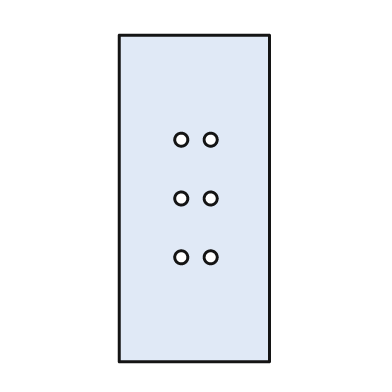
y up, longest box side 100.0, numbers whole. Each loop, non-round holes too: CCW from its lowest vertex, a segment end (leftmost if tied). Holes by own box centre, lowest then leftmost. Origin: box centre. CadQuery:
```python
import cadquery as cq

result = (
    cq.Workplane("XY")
    .moveTo(-23.0, -50.0)
    .lineTo(23.0, -50.0)
    .lineTo(23.0, 50.0)
    .lineTo(-23.0, 50.0)
    .close()
    .moveTo(-4.0, -18.0)
    .circle(2.0)
    .moveTo(5.0, -18.0)
    .circle(2.0)
    .moveTo(-4.0, 0.0)
    .circle(2.0)
    .moveTo(5.0, 0.0)
    .circle(2.0)
    .moveTo(-4.0, 18.0)
    .circle(2.0)
    .moveTo(5.0, 18.0)
    .circle(2.0)
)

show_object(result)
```